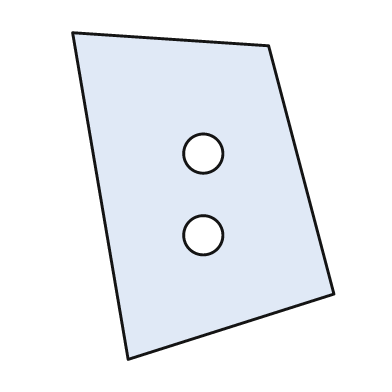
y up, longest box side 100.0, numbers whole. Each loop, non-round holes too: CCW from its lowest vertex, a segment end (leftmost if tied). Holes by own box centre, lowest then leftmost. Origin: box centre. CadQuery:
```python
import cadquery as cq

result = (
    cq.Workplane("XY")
    .moveTo(-23.0, -50.0)
    .lineTo(40.0, -30.0)
    .lineTo(20.0, 46.0)
    .lineTo(-40.0, 50.0)
    .close()
    .moveTo(0.0, -12.0)
    .circle(6.0)
    .moveTo(0.0, 13.0)
    .circle(6.0)
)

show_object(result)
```